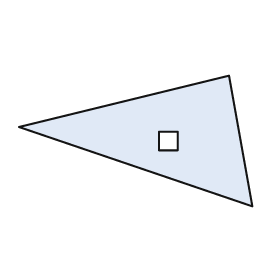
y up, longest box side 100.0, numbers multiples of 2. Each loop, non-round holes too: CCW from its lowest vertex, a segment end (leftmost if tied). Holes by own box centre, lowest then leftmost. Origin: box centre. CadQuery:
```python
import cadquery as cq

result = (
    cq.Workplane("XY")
    .moveTo(50.0, -28.0)
    .lineTo(40.0, 28.0)
    .lineTo(-50.0, 6.0)
    .close()
    .moveTo(10.0, -4.0)
    .lineTo(18.0, -4.0)
    .lineTo(18.0, 4.0)
    .lineTo(10.0, 4.0)
    .close()
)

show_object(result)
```